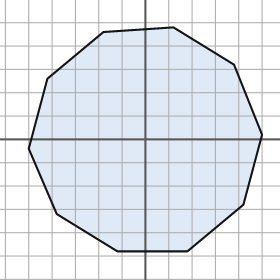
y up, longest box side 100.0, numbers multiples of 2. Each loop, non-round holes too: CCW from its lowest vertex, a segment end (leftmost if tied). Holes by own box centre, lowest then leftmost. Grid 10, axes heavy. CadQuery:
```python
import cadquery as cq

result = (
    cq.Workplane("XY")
    .moveTo(-12.0, -48.0)
    .lineTo(18.0, -48.0)
    .lineTo(42.0, -28.0)
    .lineTo(50.0, 2.0)
    .lineTo(38.0, 32.0)
    .lineTo(12.0, 48.0)
    .lineTo(-18.0, 46.0)
    .lineTo(-42.0, 26.0)
    .lineTo(-50.0, -4.0)
    .lineTo(-38.0, -32.0)
    .close()
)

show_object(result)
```